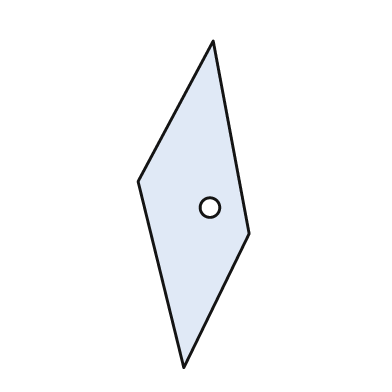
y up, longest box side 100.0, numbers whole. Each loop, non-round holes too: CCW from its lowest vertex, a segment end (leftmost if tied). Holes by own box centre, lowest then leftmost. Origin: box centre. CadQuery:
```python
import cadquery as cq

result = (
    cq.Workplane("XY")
    .moveTo(-3.0, -50.0)
    .lineTo(17.0, -9.0)
    .lineTo(6.0, 50.0)
    .lineTo(-17.0, 7.0)
    .close()
    .moveTo(5.0, -1.0)
    .circle(3.0)
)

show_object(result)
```